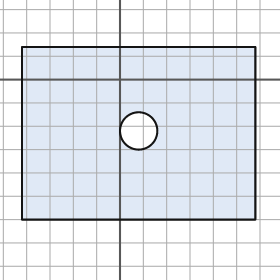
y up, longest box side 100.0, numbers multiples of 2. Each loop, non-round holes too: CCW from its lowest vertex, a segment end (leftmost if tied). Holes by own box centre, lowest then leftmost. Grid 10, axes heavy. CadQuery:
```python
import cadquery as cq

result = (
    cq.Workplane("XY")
    .moveTo(-42.0, -60.0)
    .lineTo(58.0, -60.0)
    .lineTo(58.0, 14.0)
    .lineTo(-42.0, 14.0)
    .close()
    .moveTo(8.0, -22.0)
    .circle(8.0)
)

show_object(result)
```